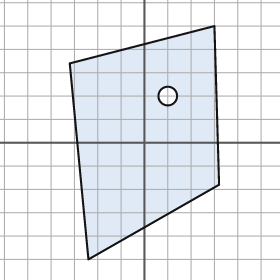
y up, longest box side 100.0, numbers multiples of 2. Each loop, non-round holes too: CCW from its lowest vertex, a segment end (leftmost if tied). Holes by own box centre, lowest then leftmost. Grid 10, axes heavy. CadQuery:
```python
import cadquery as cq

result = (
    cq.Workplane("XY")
    .moveTo(-24.0, -50.0)
    .lineTo(32.0, -18.0)
    .lineTo(30.0, 50.0)
    .lineTo(-32.0, 34.0)
    .close()
    .moveTo(10.0, 20.0)
    .circle(4.0)
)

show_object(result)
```